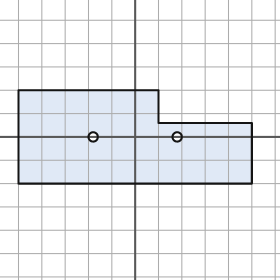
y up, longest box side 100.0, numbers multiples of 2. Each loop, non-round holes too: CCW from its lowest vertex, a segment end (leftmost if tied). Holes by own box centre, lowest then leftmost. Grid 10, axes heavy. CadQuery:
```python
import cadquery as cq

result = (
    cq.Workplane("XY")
    .moveTo(-50.0, -20.0)
    .lineTo(50.0, -20.0)
    .lineTo(50.0, 6.0)
    .lineTo(10.0, 6.0)
    .lineTo(10.0, 20.0)
    .lineTo(-50.0, 20.0)
    .close()
    .moveTo(-18.0, 0.0)
    .circle(2.0)
    .moveTo(18.0, 0.0)
    .circle(2.0)
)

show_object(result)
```